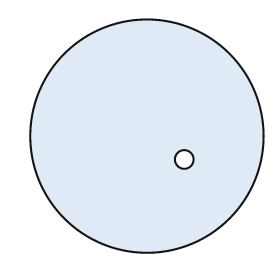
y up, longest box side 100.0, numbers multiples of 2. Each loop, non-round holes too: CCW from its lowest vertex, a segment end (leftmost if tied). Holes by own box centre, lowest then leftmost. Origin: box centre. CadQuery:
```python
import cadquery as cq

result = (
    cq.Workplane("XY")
    .moveTo(0.0, 0.0)
    .circle(50.0)
    .moveTo(16.0, -10.0)
    .circle(4.0)
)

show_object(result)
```